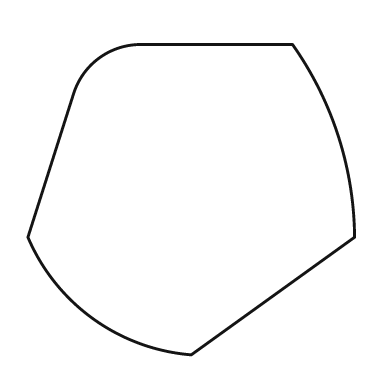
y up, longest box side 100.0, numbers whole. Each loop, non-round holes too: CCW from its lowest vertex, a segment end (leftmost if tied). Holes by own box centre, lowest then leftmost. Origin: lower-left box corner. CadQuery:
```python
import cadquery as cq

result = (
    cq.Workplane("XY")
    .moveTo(50.0, 0.0)
    .lineTo(100.0, 36.0)
    .threePointArc((95.0, 67.0), (81.0, 95.0))
    .lineTo(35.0, 95.0)
    .threePointArc((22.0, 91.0), (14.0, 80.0))
    .lineTo(0.0, 36.0)
    .threePointArc((20.0, 11.0), (50.0, 0.0))
    .close()
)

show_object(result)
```